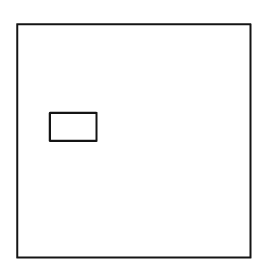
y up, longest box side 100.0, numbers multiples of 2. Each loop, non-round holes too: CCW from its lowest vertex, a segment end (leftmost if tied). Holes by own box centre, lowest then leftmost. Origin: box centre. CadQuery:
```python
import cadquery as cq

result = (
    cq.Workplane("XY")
    .moveTo(-50.0, -50.0)
    .lineTo(50.0, -50.0)
    .lineTo(50.0, 50.0)
    .lineTo(-50.0, 50.0)
    .close()
    .moveTo(-36.0, 0.0)
    .lineTo(-16.0, 0.0)
    .lineTo(-16.0, 12.0)
    .lineTo(-36.0, 12.0)
    .close()
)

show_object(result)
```